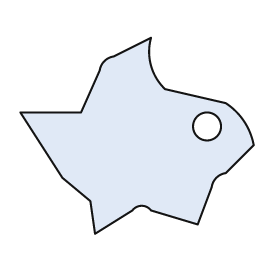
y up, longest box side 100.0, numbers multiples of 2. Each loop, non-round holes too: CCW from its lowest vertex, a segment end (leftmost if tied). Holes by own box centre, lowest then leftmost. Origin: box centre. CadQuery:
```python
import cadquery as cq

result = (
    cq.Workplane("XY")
    .moveTo(-18.0, -42.0)
    .lineTo(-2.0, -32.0)
    .threePointArc((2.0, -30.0), (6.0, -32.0))
    .lineTo(26.0, -38.0)
    .lineTo(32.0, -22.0)
    .threePointArc((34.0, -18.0), (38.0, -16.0))
    .lineTo(50.0, -4.0)
    .threePointArc((46.0, 6.0), (38.0, 14.0))
    .lineTo(12.0, 20.0)
    .threePointArc((6.0, 30.0), (6.0, 42.0))
    .lineTo(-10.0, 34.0)
    .threePointArc((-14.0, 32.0), (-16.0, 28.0))
    .lineTo(-24.0, 10.0)
    .lineTo(-50.0, 10.0)
    .lineTo(-32.0, -18.0)
    .lineTo(-20.0, -28.0)
    .close()
    .moveTo(30.0, 4.0)
    .circle(6.0)
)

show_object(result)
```